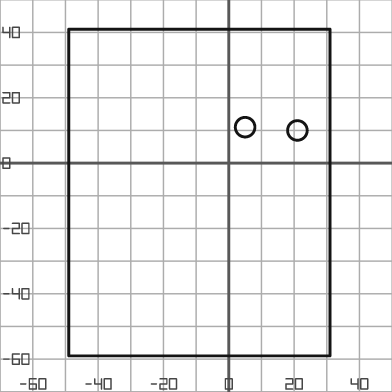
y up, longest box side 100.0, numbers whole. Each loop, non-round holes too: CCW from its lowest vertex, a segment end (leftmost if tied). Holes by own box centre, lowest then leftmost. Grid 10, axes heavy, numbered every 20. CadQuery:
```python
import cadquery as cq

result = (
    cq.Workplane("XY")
    .moveTo(-49.0, -59.0)
    .lineTo(31.0, -59.0)
    .lineTo(31.0, 41.0)
    .lineTo(-49.0, 41.0)
    .close()
    .moveTo(21.0, 10.0)
    .circle(3.0)
    .moveTo(5.0, 11.0)
    .circle(3.0)
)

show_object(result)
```